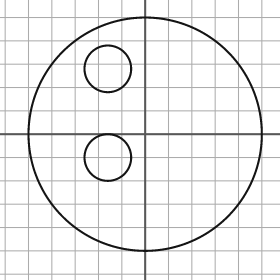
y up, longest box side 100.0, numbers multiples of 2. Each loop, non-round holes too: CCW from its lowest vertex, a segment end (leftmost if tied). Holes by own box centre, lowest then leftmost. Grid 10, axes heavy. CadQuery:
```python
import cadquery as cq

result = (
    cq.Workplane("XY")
    .moveTo(0.0, 0.0)
    .circle(50.0)
    .moveTo(-16.0, -10.0)
    .circle(10.0)
    .moveTo(-16.0, 28.0)
    .circle(10.0)
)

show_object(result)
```